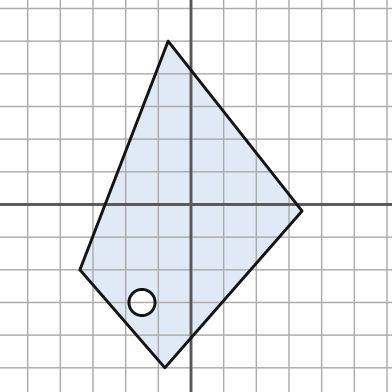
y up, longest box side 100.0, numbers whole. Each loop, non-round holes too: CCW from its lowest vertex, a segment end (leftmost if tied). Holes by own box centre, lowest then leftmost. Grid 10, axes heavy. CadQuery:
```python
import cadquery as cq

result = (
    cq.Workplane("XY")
    .moveTo(-8.0, -50.0)
    .lineTo(34.0, -2.0)
    .lineTo(-7.0, 50.0)
    .lineTo(-34.0, -20.0)
    .close()
    .moveTo(-15.0, -30.0)
    .circle(4.0)
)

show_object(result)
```